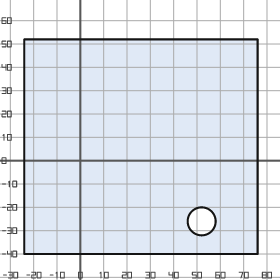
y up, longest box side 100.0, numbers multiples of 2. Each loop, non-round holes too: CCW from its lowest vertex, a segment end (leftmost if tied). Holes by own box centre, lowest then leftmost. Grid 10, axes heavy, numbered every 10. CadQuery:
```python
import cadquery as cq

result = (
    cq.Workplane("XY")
    .moveTo(-24.0, -40.0)
    .lineTo(76.0, -40.0)
    .lineTo(76.0, 52.0)
    .lineTo(-24.0, 52.0)
    .close()
    .moveTo(52.0, -26.0)
    .circle(6.0)
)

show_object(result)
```